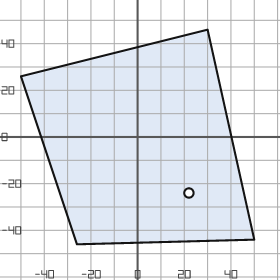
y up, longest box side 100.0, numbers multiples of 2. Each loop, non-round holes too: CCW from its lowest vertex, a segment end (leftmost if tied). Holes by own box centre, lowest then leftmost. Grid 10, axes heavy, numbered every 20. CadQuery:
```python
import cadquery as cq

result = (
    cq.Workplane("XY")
    .moveTo(-26.0, -46.0)
    .lineTo(50.0, -44.0)
    .lineTo(30.0, 46.0)
    .lineTo(-50.0, 26.0)
    .close()
    .moveTo(22.0, -24.0)
    .circle(2.0)
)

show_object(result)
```